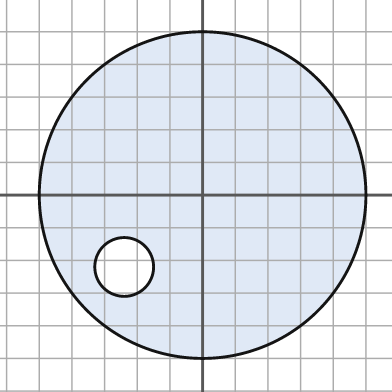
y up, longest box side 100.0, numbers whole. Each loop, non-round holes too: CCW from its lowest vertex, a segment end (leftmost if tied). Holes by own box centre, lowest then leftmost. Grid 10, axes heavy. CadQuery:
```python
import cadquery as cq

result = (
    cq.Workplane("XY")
    .moveTo(0.0, 0.0)
    .circle(50.0)
    .moveTo(-24.0, -22.0)
    .circle(9.0)
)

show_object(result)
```